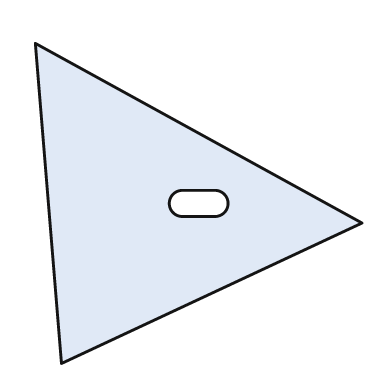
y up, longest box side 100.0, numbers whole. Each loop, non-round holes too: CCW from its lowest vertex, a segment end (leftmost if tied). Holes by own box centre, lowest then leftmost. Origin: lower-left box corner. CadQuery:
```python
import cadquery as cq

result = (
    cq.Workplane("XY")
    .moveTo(8.0, 0.0)
    .lineTo(100.0, 43.0)
    .lineTo(0.0, 98.0)
    .close()
    .moveTo(45.0, 45.0)
    .lineTo(55.0, 45.0)
    .threePointArc((59.0, 49.0), (55.0, 53.0))
    .lineTo(45.0, 53.0)
    .threePointArc((41.0, 49.0), (45.0, 45.0))
    .close()
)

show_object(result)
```